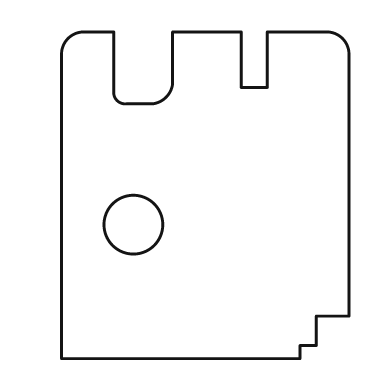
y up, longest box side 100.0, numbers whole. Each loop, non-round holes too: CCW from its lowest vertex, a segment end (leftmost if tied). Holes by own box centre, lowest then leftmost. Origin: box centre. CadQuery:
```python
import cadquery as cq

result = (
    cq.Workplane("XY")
    .moveTo(-44.0, -50.0)
    .lineTo(29.0, -50.0)
    .lineTo(29.0, -46.0)
    .lineTo(34.0, -46.0)
    .lineTo(34.0, -37.0)
    .lineTo(44.0, -37.0)
    .lineTo(44.0, 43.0)
    .threePointArc((42.0, 48.0), (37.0, 50.0))
    .lineTo(19.0, 50.0)
    .lineTo(19.0, 33.0)
    .lineTo(11.0, 33.0)
    .lineTo(11.0, 50.0)
    .lineTo(-10.0, 50.0)
    .lineTo(-10.0, 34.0)
    .threePointArc((-12.0, 30.0), (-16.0, 28.0))
    .lineTo(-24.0, 28.0)
    .threePointArc((-27.0, 29.0), (-28.0, 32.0))
    .lineTo(-28.0, 50.0)
    .lineTo(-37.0, 50.0)
    .threePointArc((-42.0, 48.0), (-44.0, 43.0))
    .close()
    .moveTo(-22.0, -9.0)
    .circle(9.0)
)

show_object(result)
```